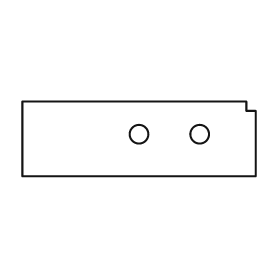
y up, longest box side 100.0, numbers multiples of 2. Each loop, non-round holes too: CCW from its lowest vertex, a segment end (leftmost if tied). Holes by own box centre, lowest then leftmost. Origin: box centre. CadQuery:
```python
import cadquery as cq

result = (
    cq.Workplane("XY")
    .moveTo(-50.0, -16.0)
    .lineTo(50.0, -16.0)
    .lineTo(50.0, 12.0)
    .lineTo(46.0, 12.0)
    .lineTo(46.0, 16.0)
    .lineTo(-50.0, 16.0)
    .close()
    .moveTo(0.0, 2.0)
    .circle(4.0)
    .moveTo(26.0, 2.0)
    .circle(4.0)
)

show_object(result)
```